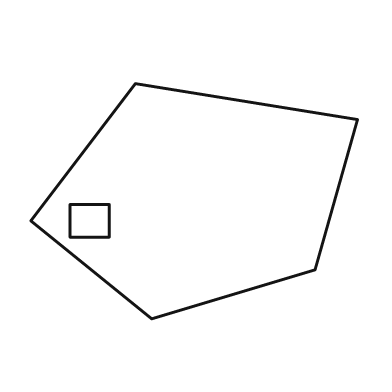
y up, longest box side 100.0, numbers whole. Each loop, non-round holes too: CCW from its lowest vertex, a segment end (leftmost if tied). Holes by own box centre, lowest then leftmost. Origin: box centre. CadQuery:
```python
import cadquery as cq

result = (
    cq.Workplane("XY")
    .moveTo(-13.0, -36.0)
    .lineTo(37.0, -21.0)
    .lineTo(50.0, 25.0)
    .lineTo(-18.0, 36.0)
    .lineTo(-50.0, -6.0)
    .close()
    .moveTo(-38.0, -11.0)
    .lineTo(-26.0, -11.0)
    .lineTo(-26.0, -1.0)
    .lineTo(-38.0, -1.0)
    .close()
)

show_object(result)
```